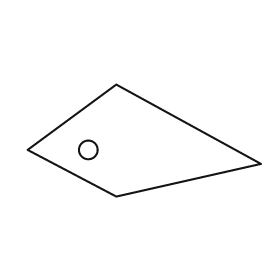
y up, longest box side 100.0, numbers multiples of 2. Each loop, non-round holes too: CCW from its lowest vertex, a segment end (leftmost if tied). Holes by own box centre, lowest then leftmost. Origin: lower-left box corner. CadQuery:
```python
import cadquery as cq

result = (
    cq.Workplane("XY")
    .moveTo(38.0, 0.0)
    .lineTo(100.0, 14.0)
    .lineTo(38.0, 48.0)
    .lineTo(0.0, 20.0)
    .close()
    .moveTo(26.0, 20.0)
    .circle(4.0)
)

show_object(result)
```